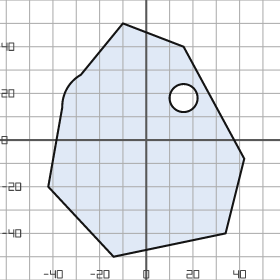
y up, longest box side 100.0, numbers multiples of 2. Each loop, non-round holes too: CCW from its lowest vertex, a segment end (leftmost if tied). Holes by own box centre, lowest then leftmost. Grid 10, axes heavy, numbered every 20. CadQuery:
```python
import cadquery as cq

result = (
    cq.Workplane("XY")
    .moveTo(-14.0, -50.0)
    .lineTo(34.0, -40.0)
    .lineTo(42.0, -8.0)
    .lineTo(16.0, 40.0)
    .lineTo(-10.0, 50.0)
    .lineTo(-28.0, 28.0)
    .threePointArc((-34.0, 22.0), (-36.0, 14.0))
    .lineTo(-42.0, -20.0)
    .close()
    .moveTo(16.0, 18.0)
    .circle(6.0)
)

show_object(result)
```